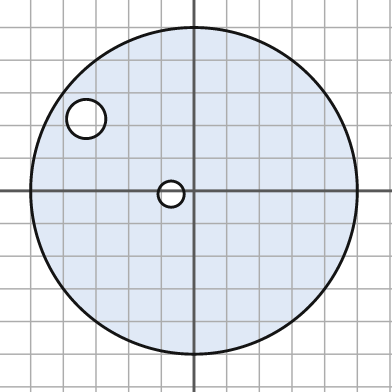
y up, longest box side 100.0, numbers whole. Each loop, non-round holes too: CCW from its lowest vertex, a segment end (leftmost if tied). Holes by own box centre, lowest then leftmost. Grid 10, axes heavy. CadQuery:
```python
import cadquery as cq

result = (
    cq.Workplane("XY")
    .moveTo(0.0, 0.0)
    .circle(50.0)
    .moveTo(-7.0, -1.0)
    .circle(4.0)
    .moveTo(-33.0, 22.0)
    .circle(6.0)
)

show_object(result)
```